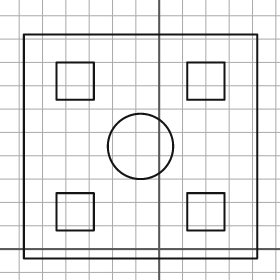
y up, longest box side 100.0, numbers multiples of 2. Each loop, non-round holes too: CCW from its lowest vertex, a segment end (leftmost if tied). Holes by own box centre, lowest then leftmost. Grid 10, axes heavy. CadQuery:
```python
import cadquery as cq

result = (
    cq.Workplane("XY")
    .moveTo(-58.0, -4.0)
    .lineTo(42.0, -4.0)
    .lineTo(42.0, 92.0)
    .lineTo(-58.0, 92.0)
    .close()
    .moveTo(-44.0, 8.0)
    .lineTo(-28.0, 8.0)
    .lineTo(-28.0, 24.0)
    .lineTo(-44.0, 24.0)
    .close()
    .moveTo(12.0, 8.0)
    .lineTo(28.0, 8.0)
    .lineTo(28.0, 24.0)
    .lineTo(12.0, 24.0)
    .close()
    .moveTo(-8.0, 44.0)
    .circle(14.0)
    .moveTo(-44.0, 64.0)
    .lineTo(-28.0, 64.0)
    .lineTo(-28.0, 80.0)
    .lineTo(-44.0, 80.0)
    .close()
    .moveTo(12.0, 64.0)
    .lineTo(28.0, 64.0)
    .lineTo(28.0, 80.0)
    .lineTo(12.0, 80.0)
    .close()
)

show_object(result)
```